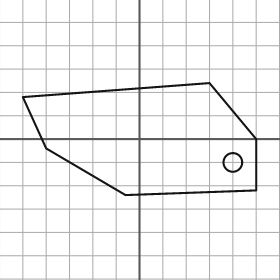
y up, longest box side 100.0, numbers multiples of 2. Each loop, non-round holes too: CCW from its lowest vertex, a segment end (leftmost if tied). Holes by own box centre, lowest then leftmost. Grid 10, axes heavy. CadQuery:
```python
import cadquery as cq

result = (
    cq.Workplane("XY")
    .moveTo(-6.0, -24.0)
    .lineTo(50.0, -22.0)
    .lineTo(50.0, 0.0)
    .lineTo(30.0, 24.0)
    .lineTo(-50.0, 18.0)
    .lineTo(-40.0, -4.0)
    .close()
    .moveTo(40.0, -10.0)
    .circle(4.0)
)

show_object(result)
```